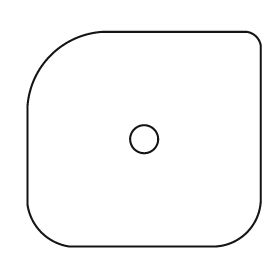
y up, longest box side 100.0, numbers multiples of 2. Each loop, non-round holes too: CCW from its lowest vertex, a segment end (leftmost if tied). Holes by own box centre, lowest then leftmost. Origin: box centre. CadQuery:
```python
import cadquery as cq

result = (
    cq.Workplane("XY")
    .moveTo(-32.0, -46.0)
    .lineTo(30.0, -46.0)
    .threePointArc((44.0, -40.0), (50.0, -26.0))
    .lineTo(50.0, 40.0)
    .threePointArc((48.0, 44.0), (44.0, 46.0))
    .lineTo(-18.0, 46.0)
    .threePointArc((-40.0, 36.0), (-50.0, 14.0))
    .lineTo(-50.0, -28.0)
    .threePointArc((-44.0, -40.0), (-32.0, -46.0))
    .close()
    .moveTo(0.0, 0.0)
    .circle(6.0)
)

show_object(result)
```